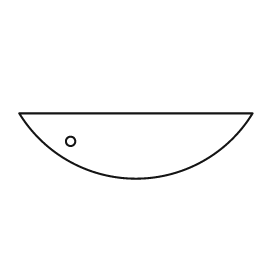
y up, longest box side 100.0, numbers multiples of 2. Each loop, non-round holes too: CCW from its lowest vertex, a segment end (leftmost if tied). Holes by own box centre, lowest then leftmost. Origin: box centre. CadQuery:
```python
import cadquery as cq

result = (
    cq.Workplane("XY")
    .moveTo(-50.0, 14.0)
    .threePointArc((0.0, -14.0), (50.0, 14.0))
    .close()
    .moveTo(-28.0, 2.0)
    .circle(2.0)
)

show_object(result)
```